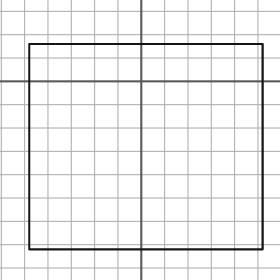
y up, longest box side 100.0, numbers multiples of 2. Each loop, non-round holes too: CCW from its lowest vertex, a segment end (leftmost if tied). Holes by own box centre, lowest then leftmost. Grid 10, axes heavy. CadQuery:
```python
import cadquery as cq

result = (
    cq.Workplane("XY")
    .moveTo(-48.0, -72.0)
    .lineTo(52.0, -72.0)
    .lineTo(52.0, 16.0)
    .lineTo(-48.0, 16.0)
    .close()
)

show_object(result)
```